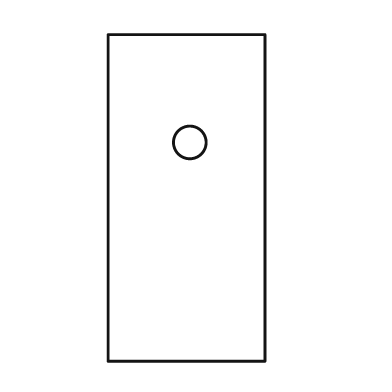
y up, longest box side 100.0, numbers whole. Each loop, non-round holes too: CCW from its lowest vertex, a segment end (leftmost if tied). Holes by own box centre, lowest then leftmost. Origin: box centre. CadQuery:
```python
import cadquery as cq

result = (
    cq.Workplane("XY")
    .moveTo(-24.0, -50.0)
    .lineTo(24.0, -50.0)
    .lineTo(24.0, 50.0)
    .lineTo(-24.0, 50.0)
    .close()
    .moveTo(1.0, 17.0)
    .circle(5.0)
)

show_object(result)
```